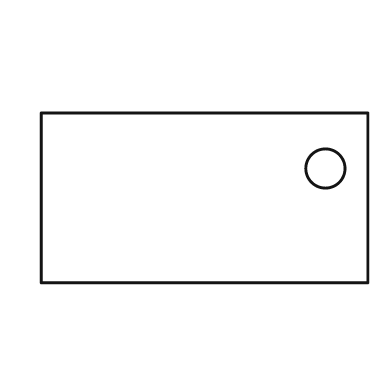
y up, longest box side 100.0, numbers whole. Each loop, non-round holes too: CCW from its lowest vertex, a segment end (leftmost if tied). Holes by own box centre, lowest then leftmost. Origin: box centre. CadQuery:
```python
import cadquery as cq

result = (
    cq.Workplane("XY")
    .moveTo(-50.0, -26.0)
    .lineTo(50.0, -26.0)
    .lineTo(50.0, 26.0)
    .lineTo(-50.0, 26.0)
    .close()
    .moveTo(37.0, 9.0)
    .circle(6.0)
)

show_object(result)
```